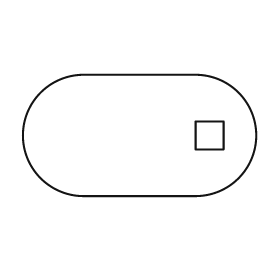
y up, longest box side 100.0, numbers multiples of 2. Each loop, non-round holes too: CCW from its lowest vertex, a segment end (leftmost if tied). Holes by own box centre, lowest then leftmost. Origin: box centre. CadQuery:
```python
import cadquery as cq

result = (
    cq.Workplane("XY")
    .moveTo(-24.0, -26.0)
    .lineTo(24.0, -26.0)
    .threePointArc((50.0, 0.0), (24.0, 26.0))
    .lineTo(-24.0, 26.0)
    .threePointArc((-50.0, 0.0), (-24.0, -26.0))
    .close()
    .moveTo(24.0, -6.0)
    .lineTo(36.0, -6.0)
    .lineTo(36.0, 6.0)
    .lineTo(24.0, 6.0)
    .close()
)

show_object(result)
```